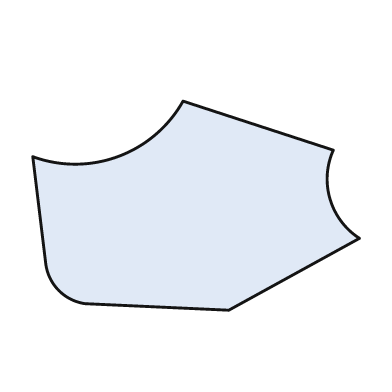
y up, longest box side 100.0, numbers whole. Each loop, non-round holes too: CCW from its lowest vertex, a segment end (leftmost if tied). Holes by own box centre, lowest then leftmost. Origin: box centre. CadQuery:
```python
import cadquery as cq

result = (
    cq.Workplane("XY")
    .moveTo(10.0, -32.0)
    .lineTo(50.0, -10.0)
    .threePointArc((41.0, 2.0), (42.0, 17.0))
    .lineTo(-4.0, 32.0)
    .threePointArc((-24.0, 15.0), (-50.0, 15.0))
    .lineTo(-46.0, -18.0)
    .threePointArc((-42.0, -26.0), (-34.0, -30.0))
    .close()
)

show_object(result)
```